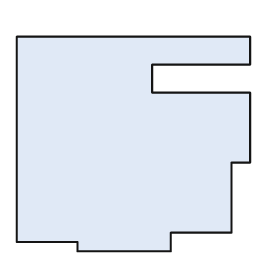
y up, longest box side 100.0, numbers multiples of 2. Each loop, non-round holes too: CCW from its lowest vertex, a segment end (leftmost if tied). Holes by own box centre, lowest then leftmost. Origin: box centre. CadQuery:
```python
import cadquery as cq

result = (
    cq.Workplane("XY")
    .moveTo(-24.0, -46.0)
    .lineTo(16.0, -46.0)
    .lineTo(16.0, -38.0)
    .lineTo(42.0, -38.0)
    .lineTo(42.0, -8.0)
    .lineTo(50.0, -8.0)
    .lineTo(50.0, 22.0)
    .lineTo(8.0, 22.0)
    .lineTo(8.0, 34.0)
    .lineTo(50.0, 34.0)
    .lineTo(50.0, 46.0)
    .lineTo(-50.0, 46.0)
    .lineTo(-50.0, -42.0)
    .lineTo(-24.0, -42.0)
    .close()
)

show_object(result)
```